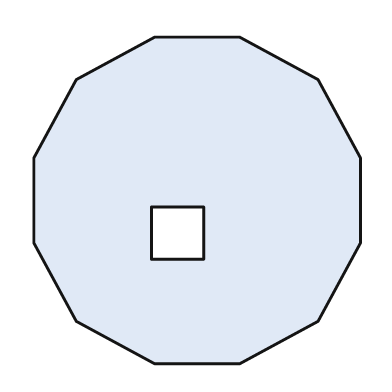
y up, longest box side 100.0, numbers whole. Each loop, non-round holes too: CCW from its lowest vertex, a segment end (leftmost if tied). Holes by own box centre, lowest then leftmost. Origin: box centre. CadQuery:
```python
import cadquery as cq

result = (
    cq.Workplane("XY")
    .moveTo(-13.0, -50.0)
    .lineTo(13.0, -50.0)
    .lineTo(37.0, -37.0)
    .lineTo(50.0, -13.0)
    .lineTo(50.0, 13.0)
    .lineTo(37.0, 37.0)
    .lineTo(13.0, 50.0)
    .lineTo(-13.0, 50.0)
    .lineTo(-37.0, 37.0)
    .lineTo(-50.0, 13.0)
    .lineTo(-50.0, -13.0)
    .lineTo(-37.0, -37.0)
    .close()
    .moveTo(-14.0, -18.0)
    .lineTo(2.0, -18.0)
    .lineTo(2.0, -2.0)
    .lineTo(-14.0, -2.0)
    .close()
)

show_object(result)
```